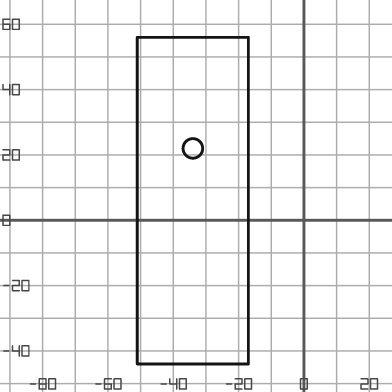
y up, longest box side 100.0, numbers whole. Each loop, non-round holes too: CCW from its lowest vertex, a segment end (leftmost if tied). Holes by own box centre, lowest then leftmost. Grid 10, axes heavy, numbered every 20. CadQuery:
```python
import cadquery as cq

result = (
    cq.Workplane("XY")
    .moveTo(-51.0, -44.0)
    .lineTo(-17.0, -44.0)
    .lineTo(-17.0, 56.0)
    .lineTo(-51.0, 56.0)
    .close()
    .moveTo(-34.0, 22.0)
    .circle(3.0)
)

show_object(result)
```